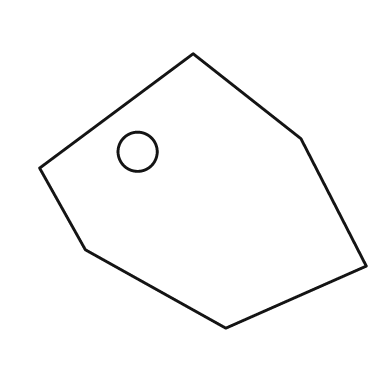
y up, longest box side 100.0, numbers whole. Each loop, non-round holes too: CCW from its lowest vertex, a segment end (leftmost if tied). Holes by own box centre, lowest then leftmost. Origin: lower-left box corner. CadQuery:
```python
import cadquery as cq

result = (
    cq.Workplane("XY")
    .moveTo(57.0, 0.0)
    .lineTo(100.0, 19.0)
    .lineTo(80.0, 58.0)
    .lineTo(47.0, 84.0)
    .lineTo(0.0, 49.0)
    .lineTo(14.0, 24.0)
    .close()
    .moveTo(30.0, 54.0)
    .circle(6.0)
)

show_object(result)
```